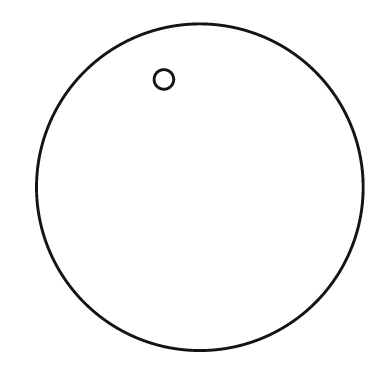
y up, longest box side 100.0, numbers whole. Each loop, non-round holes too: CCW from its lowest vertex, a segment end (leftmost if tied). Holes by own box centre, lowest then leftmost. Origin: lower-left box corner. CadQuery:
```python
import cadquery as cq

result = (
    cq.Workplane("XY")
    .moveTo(50.0, 50.0)
    .circle(50.0)
    .moveTo(39.0, 83.0)
    .circle(3.0)
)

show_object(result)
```